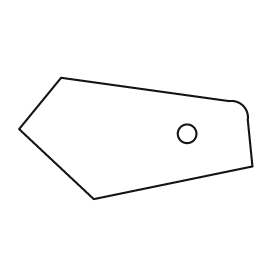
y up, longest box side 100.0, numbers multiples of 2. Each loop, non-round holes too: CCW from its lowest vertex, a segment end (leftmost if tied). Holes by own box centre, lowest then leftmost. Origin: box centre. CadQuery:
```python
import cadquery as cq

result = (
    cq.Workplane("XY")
    .moveTo(-18.0, -26.0)
    .lineTo(50.0, -12.0)
    .lineTo(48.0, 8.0)
    .threePointArc((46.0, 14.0), (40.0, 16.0))
    .lineTo(-32.0, 26.0)
    .lineTo(-50.0, 4.0)
    .close()
    .moveTo(22.0, 2.0)
    .circle(4.0)
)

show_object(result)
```